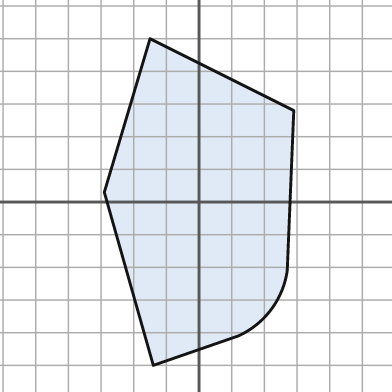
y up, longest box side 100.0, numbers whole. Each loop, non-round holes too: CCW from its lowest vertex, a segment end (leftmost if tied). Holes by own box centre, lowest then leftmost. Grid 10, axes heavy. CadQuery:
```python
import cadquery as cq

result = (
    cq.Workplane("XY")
    .moveTo(-14.0, -50.0)
    .lineTo(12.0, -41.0)
    .threePointArc((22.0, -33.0), (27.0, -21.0))
    .lineTo(29.0, 28.0)
    .lineTo(-15.0, 50.0)
    .lineTo(-29.0, 3.0)
    .close()
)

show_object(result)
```